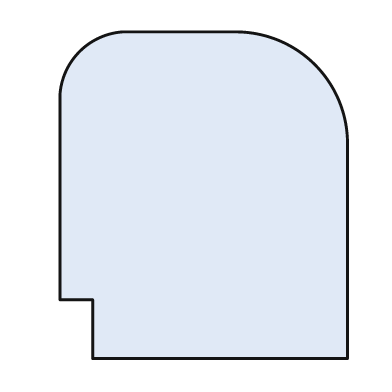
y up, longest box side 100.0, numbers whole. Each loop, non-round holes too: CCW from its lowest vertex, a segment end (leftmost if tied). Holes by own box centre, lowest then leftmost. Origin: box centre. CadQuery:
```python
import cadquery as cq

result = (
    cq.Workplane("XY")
    .moveTo(-34.0, -50.0)
    .lineTo(44.0, -50.0)
    .lineTo(44.0, 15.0)
    .threePointArc((34.0, 40.0), (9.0, 50.0))
    .lineTo(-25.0, 50.0)
    .threePointArc((-38.0, 44.0), (-44.0, 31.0))
    .lineTo(-44.0, -32.0)
    .lineTo(-34.0, -32.0)
    .close()
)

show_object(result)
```